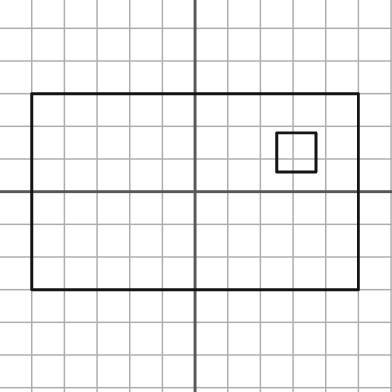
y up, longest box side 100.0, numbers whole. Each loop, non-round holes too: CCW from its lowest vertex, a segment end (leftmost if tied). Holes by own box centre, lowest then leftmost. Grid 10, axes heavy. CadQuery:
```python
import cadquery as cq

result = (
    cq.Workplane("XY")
    .moveTo(-50.0, -30.0)
    .lineTo(50.0, -30.0)
    .lineTo(50.0, 30.0)
    .lineTo(-50.0, 30.0)
    .close()
    .moveTo(25.0, 6.0)
    .lineTo(37.0, 6.0)
    .lineTo(37.0, 18.0)
    .lineTo(25.0, 18.0)
    .close()
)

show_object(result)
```